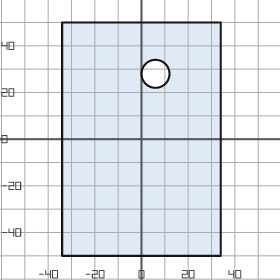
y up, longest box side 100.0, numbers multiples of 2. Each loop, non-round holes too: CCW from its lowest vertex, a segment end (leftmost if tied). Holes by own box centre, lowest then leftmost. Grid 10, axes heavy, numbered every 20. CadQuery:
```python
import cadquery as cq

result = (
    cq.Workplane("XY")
    .moveTo(-34.0, -50.0)
    .lineTo(34.0, -50.0)
    .lineTo(34.0, 50.0)
    .lineTo(-34.0, 50.0)
    .close()
    .moveTo(6.0, 28.0)
    .circle(6.0)
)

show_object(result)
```